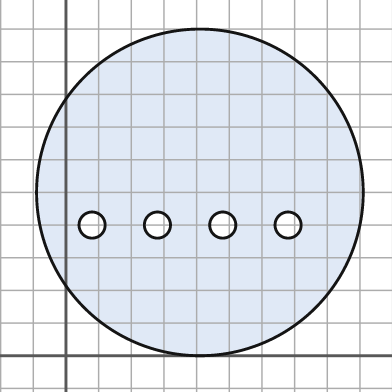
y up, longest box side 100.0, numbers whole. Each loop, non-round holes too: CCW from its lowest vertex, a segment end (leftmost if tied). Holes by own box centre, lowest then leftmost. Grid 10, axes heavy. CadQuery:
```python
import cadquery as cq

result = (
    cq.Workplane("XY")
    .moveTo(41.0, 50.0)
    .circle(50.0)
    .moveTo(8.0, 40.0)
    .circle(4.0)
    .moveTo(28.0, 40.0)
    .circle(4.0)
    .moveTo(48.0, 40.0)
    .circle(4.0)
    .moveTo(68.0, 40.0)
    .circle(4.0)
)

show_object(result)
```